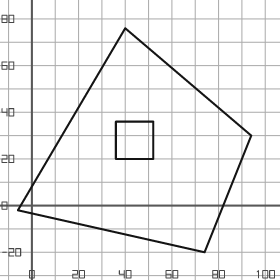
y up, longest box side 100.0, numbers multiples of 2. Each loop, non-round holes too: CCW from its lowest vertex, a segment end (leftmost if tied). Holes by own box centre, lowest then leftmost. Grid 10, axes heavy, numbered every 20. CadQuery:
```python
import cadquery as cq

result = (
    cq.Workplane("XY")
    .moveTo(74.0, -20.0)
    .lineTo(94.0, 30.0)
    .lineTo(40.0, 76.0)
    .lineTo(-6.0, -2.0)
    .close()
    .moveTo(36.0, 20.0)
    .lineTo(52.0, 20.0)
    .lineTo(52.0, 36.0)
    .lineTo(36.0, 36.0)
    .close()
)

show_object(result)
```